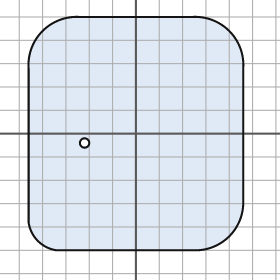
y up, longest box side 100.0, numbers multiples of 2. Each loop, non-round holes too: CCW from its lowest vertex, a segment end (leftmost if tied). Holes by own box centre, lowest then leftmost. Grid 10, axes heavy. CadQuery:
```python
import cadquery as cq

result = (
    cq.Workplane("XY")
    .moveTo(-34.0, -50.0)
    .lineTo(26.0, -50.0)
    .threePointArc((40.0, -44.0), (46.0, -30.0))
    .lineTo(46.0, 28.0)
    .threePointArc((40.0, 44.0), (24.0, 50.0))
    .lineTo(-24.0, 50.0)
    .threePointArc((-40.0, 44.0), (-46.0, 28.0))
    .lineTo(-46.0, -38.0)
    .threePointArc((-42.0, -46.0), (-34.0, -50.0))
    .close()
    .moveTo(-22.0, -4.0)
    .circle(2.0)
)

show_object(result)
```